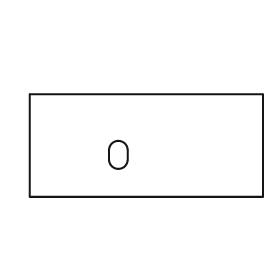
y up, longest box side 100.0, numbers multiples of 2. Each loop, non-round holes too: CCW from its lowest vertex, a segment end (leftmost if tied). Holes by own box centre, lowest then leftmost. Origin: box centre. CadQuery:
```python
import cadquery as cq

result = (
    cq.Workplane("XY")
    .moveTo(-50.0, -22.0)
    .lineTo(50.0, -22.0)
    .lineTo(50.0, 22.0)
    .lineTo(-50.0, 22.0)
    .close()
    .moveTo(-16.0, -6.0)
    .threePointArc((-12.0, -10.0), (-8.0, -6.0))
    .lineTo(-8.0, -2.0)
    .threePointArc((-12.0, 2.0), (-16.0, -2.0))
    .close()
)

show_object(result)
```